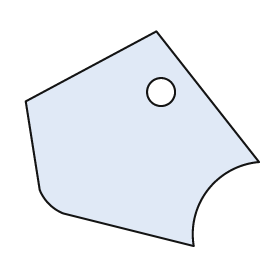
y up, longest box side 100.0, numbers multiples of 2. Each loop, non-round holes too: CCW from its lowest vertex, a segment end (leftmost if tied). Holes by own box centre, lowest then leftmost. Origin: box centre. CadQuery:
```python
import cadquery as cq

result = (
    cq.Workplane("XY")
    .moveTo(22.0, -46.0)
    .threePointArc((28.0, -22.0), (50.0, -10.0))
    .lineTo(6.0, 46.0)
    .lineTo(-50.0, 16.0)
    .lineTo(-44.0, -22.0)
    .threePointArc((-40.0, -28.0), (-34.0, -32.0))
    .close()
    .moveTo(8.0, 20.0)
    .circle(6.0)
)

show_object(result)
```